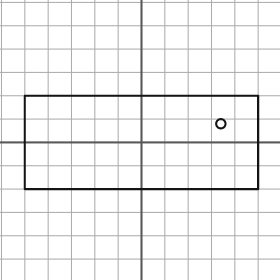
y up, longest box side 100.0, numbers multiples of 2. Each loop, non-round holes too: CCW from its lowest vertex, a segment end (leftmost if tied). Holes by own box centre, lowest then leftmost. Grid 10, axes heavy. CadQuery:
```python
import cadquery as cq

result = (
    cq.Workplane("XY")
    .moveTo(-50.0, -20.0)
    .lineTo(50.0, -20.0)
    .lineTo(50.0, 20.0)
    .lineTo(-50.0, 20.0)
    .close()
    .moveTo(34.0, 8.0)
    .circle(2.0)
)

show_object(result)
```